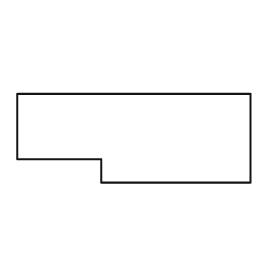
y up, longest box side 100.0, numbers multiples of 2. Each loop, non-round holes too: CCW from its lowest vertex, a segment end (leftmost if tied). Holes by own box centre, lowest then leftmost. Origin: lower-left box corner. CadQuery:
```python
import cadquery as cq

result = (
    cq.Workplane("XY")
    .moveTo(36.0, 0.0)
    .lineTo(100.0, 0.0)
    .lineTo(100.0, 38.0)
    .lineTo(0.0, 38.0)
    .lineTo(0.0, 10.0)
    .lineTo(36.0, 10.0)
    .close()
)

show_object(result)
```